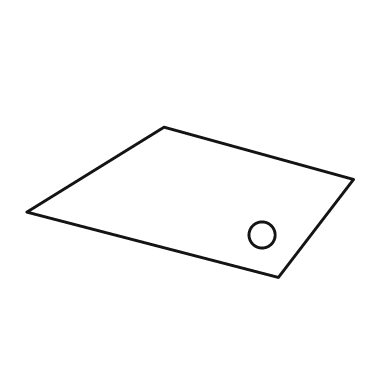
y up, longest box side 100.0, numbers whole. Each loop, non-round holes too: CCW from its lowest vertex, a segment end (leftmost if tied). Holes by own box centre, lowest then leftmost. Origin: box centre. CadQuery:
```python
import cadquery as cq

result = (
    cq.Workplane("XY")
    .moveTo(27.0, -23.0)
    .lineTo(50.0, 7.0)
    .lineTo(-8.0, 23.0)
    .lineTo(-50.0, -3.0)
    .close()
    .moveTo(22.0, -10.0)
    .circle(4.0)
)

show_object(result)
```